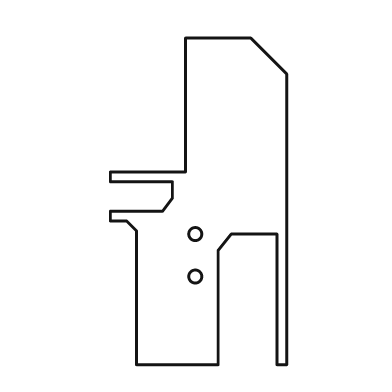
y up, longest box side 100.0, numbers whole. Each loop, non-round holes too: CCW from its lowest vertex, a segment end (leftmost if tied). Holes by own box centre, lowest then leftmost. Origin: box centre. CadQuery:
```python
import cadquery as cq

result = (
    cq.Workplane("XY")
    .moveTo(-19.0, -50.0)
    .lineTo(6.0, -50.0)
    .lineTo(6.0, -15.0)
    .lineTo(10.0, -10.0)
    .lineTo(24.0, -10.0)
    .lineTo(24.0, -50.0)
    .lineTo(27.0, -50.0)
    .lineTo(27.0, 39.0)
    .lineTo(16.0, 50.0)
    .lineTo(-4.0, 50.0)
    .lineTo(-4.0, 9.0)
    .lineTo(-27.0, 9.0)
    .lineTo(-27.0, 6.0)
    .lineTo(-8.0, 6.0)
    .lineTo(-8.0, 1.0)
    .lineTo(-11.0, -3.0)
    .lineTo(-27.0, -3.0)
    .lineTo(-27.0, -6.0)
    .lineTo(-22.0, -6.0)
    .lineTo(-19.0, -9.0)
    .close()
    .moveTo(-1.0, -23.0)
    .circle(2.0)
    .moveTo(-1.0, -10.0)
    .circle(2.0)
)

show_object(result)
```